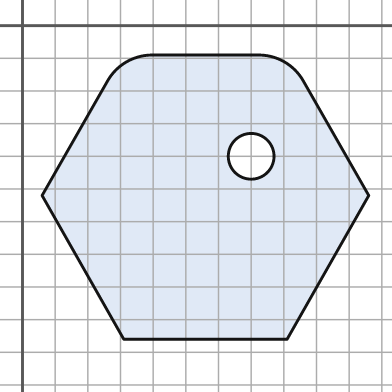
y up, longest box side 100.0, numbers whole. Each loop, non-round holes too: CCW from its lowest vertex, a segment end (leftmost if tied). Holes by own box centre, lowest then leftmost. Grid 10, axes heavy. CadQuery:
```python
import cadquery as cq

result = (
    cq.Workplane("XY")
    .moveTo(31.0, -96.0)
    .lineTo(81.0, -96.0)
    .lineTo(106.0, -52.0)
    .lineTo(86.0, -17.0)
    .threePointArc((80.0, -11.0), (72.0, -9.0))
    .lineTo(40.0, -9.0)
    .threePointArc((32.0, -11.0), (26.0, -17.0))
    .lineTo(6.0, -52.0)
    .close()
    .moveTo(70.0, -40.0)
    .circle(7.0)
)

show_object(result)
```